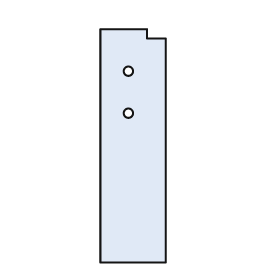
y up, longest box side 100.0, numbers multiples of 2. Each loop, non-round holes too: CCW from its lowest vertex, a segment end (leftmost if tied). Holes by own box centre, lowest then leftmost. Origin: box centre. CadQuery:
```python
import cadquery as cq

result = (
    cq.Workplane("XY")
    .moveTo(-14.0, -50.0)
    .lineTo(14.0, -50.0)
    .lineTo(14.0, 46.0)
    .lineTo(6.0, 46.0)
    .lineTo(6.0, 50.0)
    .lineTo(-14.0, 50.0)
    .close()
    .moveTo(-2.0, 14.0)
    .circle(2.0)
    .moveTo(-2.0, 32.0)
    .circle(2.0)
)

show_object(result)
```